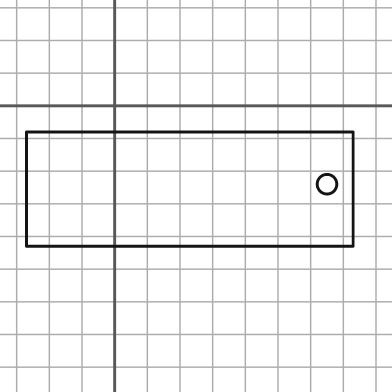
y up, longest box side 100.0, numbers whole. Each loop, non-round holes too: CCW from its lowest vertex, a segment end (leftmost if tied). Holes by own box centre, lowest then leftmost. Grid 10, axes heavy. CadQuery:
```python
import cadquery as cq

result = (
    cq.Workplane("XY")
    .moveTo(-27.0, -43.0)
    .lineTo(73.0, -43.0)
    .lineTo(73.0, -8.0)
    .lineTo(-27.0, -8.0)
    .close()
    .moveTo(65.0, -24.0)
    .circle(3.0)
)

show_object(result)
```